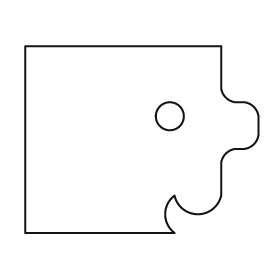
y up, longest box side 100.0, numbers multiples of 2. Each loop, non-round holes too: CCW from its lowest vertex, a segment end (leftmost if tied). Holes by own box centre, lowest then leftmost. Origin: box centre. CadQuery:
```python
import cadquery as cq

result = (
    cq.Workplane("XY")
    .moveTo(-50.0, -40.0)
    .lineTo(14.0, -40.0)
    .threePointArc((10.0, -32.0), (14.0, -24.0))
    .threePointArc((24.0, -32.0), (34.0, -24.0))
    .lineTo(34.0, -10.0)
    .threePointArc((36.0, -6.0), (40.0, -4.0))
    .lineTo(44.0, -4.0)
    .threePointArc((48.0, -2.0), (50.0, 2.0))
    .lineTo(50.0, 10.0)
    .threePointArc((48.0, 14.0), (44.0, 16.0))
    .lineTo(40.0, 16.0)
    .threePointArc((36.0, 18.0), (34.0, 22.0))
    .lineTo(34.0, 40.0)
    .lineTo(-50.0, 40.0)
    .close()
    .moveTo(12.0, 10.0)
    .circle(6.0)
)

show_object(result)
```